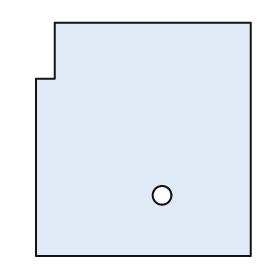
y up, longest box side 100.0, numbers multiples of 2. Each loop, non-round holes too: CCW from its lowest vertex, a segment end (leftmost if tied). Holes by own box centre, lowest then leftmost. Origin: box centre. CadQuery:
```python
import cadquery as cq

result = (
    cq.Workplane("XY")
    .moveTo(-46.0, -50.0)
    .lineTo(46.0, -50.0)
    .lineTo(46.0, 50.0)
    .lineTo(-38.0, 50.0)
    .lineTo(-38.0, 26.0)
    .lineTo(-46.0, 26.0)
    .close()
    .moveTo(8.0, -24.0)
    .circle(4.0)
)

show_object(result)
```